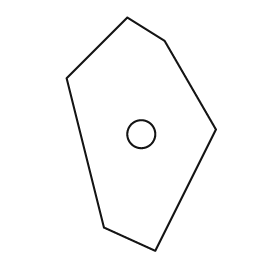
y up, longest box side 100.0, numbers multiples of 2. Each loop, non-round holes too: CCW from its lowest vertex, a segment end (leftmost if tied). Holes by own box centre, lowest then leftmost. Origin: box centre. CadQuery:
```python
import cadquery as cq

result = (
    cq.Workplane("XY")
    .moveTo(6.0, -50.0)
    .lineTo(32.0, 2.0)
    .lineTo(10.0, 40.0)
    .lineTo(-6.0, 50.0)
    .lineTo(-32.0, 24.0)
    .lineTo(-16.0, -40.0)
    .close()
    .moveTo(0.0, 0.0)
    .circle(6.0)
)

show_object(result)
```